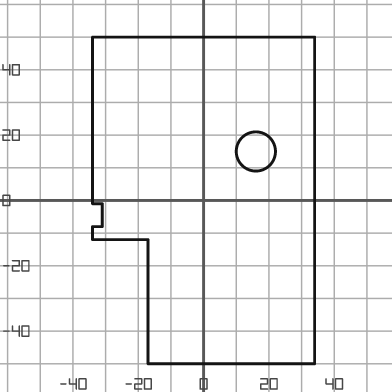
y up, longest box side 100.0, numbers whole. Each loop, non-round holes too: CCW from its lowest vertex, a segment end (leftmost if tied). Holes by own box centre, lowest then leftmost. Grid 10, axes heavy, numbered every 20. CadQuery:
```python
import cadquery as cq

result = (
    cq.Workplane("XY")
    .moveTo(-17.0, -50.0)
    .lineTo(34.0, -50.0)
    .lineTo(34.0, 50.0)
    .lineTo(-34.0, 50.0)
    .lineTo(-34.0, -1.0)
    .lineTo(-31.0, -1.0)
    .lineTo(-31.0, -8.0)
    .lineTo(-34.0, -8.0)
    .lineTo(-34.0, -12.0)
    .lineTo(-17.0, -12.0)
    .close()
    .moveTo(16.0, 15.0)
    .circle(6.0)
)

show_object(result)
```